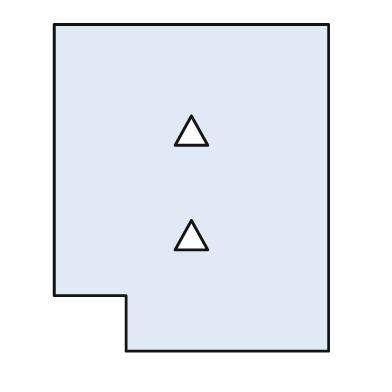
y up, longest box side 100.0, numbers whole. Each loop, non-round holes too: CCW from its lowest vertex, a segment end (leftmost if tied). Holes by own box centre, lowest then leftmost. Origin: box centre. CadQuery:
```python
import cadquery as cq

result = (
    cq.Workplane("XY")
    .moveTo(-20.0, -50.0)
    .lineTo(42.0, -50.0)
    .lineTo(42.0, 50.0)
    .lineTo(-42.0, 50.0)
    .lineTo(-42.0, -33.0)
    .lineTo(-20.0, -33.0)
    .close()
    .moveTo(-5.0, -19.0)
    .lineTo(5.0, -19.0)
    .lineTo(0.0, -10.0)
    .close()
    .moveTo(-5.0, 13.0)
    .lineTo(5.0, 13.0)
    .lineTo(0.0, 22.0)
    .close()
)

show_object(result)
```